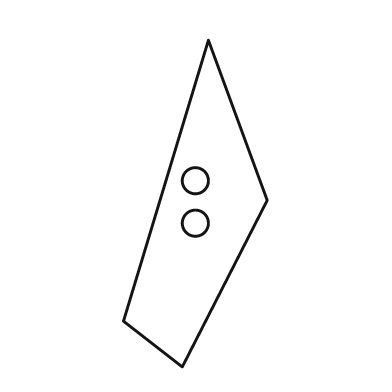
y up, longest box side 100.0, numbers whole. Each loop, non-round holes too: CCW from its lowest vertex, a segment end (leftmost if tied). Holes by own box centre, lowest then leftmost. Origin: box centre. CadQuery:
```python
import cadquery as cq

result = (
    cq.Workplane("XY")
    .moveTo(-4.0, -50.0)
    .lineTo(22.0, 1.0)
    .lineTo(4.0, 50.0)
    .lineTo(-22.0, -36.0)
    .close()
    .moveTo(0.0, -6.0)
    .circle(4.0)
    .moveTo(0.0, 7.0)
    .circle(4.0)
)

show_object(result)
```